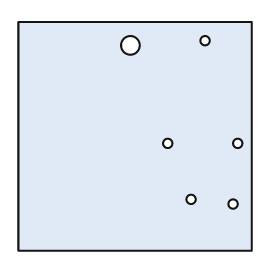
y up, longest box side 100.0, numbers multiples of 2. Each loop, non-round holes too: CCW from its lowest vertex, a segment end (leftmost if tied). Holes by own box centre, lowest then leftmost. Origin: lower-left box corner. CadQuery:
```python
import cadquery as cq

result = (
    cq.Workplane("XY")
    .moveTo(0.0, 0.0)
    .lineTo(100.0, 0.0)
    .lineTo(100.0, 98.0)
    .lineTo(0.0, 98.0)
    .close()
    .moveTo(92.0, 20.0)
    .circle(2.0)
    .moveTo(74.0, 22.0)
    .circle(2.0)
    .moveTo(64.0, 46.0)
    .circle(2.0)
    .moveTo(94.0, 46.0)
    .circle(2.0)
    .moveTo(48.0, 88.0)
    .circle(4.0)
    .moveTo(80.0, 90.0)
    .circle(2.0)
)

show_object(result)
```